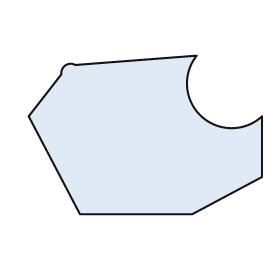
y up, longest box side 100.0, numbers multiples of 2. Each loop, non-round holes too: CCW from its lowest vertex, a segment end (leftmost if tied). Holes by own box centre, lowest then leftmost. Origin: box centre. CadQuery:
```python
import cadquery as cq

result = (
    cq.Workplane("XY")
    .moveTo(-28.0, -34.0)
    .lineTo(20.0, -34.0)
    .lineTo(50.0, -18.0)
    .lineTo(50.0, 8.0)
    .threePointArc((24.0, 8.0), (22.0, 34.0))
    .lineTo(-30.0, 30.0)
    .threePointArc((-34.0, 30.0), (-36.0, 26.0))
    .lineTo(-50.0, 8.0)
    .close()
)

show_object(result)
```